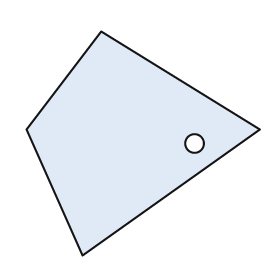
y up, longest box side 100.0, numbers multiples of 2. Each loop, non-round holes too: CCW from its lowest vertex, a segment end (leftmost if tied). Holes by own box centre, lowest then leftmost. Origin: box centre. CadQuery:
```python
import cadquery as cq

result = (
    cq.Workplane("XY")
    .moveTo(-26.0, -48.0)
    .lineTo(50.0, 6.0)
    .lineTo(-18.0, 48.0)
    .lineTo(-50.0, 6.0)
    .close()
    .moveTo(22.0, 0.0)
    .circle(4.0)
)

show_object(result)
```